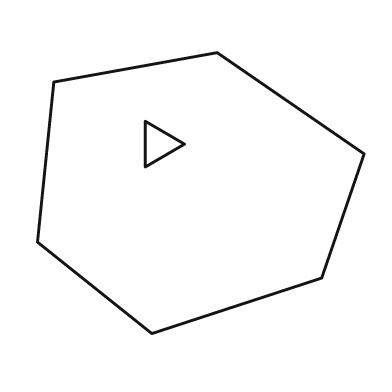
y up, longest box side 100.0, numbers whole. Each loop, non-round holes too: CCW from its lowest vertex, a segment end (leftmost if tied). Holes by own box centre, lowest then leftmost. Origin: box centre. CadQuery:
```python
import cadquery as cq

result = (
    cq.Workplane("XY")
    .moveTo(-15.0, -43.0)
    .lineTo(37.0, -26.0)
    .lineTo(50.0, 12.0)
    .lineTo(5.0, 43.0)
    .lineTo(-45.0, 34.0)
    .lineTo(-50.0, -15.0)
    .close()
    .moveTo(-17.0, 8.0)
    .lineTo(-5.0, 15.0)
    .lineTo(-17.0, 22.0)
    .close()
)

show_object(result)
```